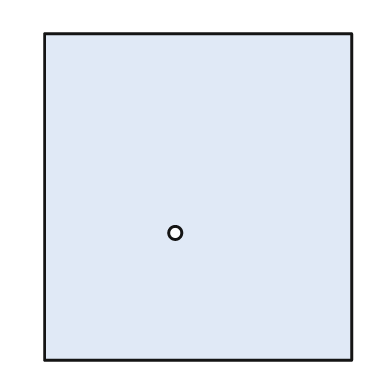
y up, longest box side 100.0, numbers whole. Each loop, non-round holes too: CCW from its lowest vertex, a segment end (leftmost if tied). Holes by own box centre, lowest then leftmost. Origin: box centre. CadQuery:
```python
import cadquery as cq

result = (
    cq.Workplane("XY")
    .moveTo(-47.0, -50.0)
    .lineTo(47.0, -50.0)
    .lineTo(47.0, 50.0)
    .lineTo(-47.0, 50.0)
    .close()
    .moveTo(-7.0, -11.0)
    .circle(2.0)
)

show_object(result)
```